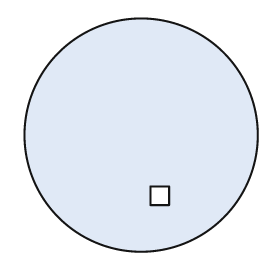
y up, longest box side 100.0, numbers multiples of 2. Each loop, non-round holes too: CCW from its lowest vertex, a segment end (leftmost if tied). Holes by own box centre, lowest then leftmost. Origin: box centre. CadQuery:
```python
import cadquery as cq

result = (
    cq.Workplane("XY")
    .moveTo(0.0, 0.0)
    .circle(50.0)
    .moveTo(4.0, -30.0)
    .lineTo(12.0, -30.0)
    .lineTo(12.0, -22.0)
    .lineTo(4.0, -22.0)
    .close()
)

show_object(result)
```